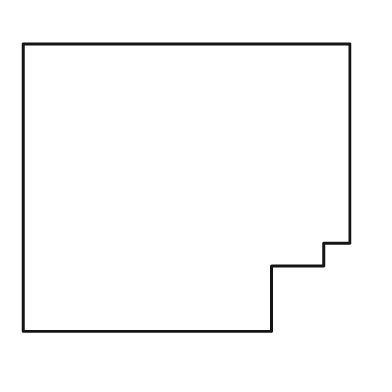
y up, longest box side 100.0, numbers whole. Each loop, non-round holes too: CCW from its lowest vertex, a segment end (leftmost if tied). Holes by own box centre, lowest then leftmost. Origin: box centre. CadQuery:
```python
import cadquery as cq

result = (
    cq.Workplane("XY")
    .moveTo(-50.0, -44.0)
    .lineTo(26.0, -44.0)
    .lineTo(26.0, -24.0)
    .lineTo(42.0, -24.0)
    .lineTo(42.0, -17.0)
    .lineTo(50.0, -17.0)
    .lineTo(50.0, 44.0)
    .lineTo(-50.0, 44.0)
    .close()
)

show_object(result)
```